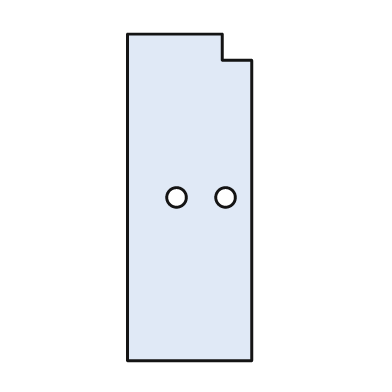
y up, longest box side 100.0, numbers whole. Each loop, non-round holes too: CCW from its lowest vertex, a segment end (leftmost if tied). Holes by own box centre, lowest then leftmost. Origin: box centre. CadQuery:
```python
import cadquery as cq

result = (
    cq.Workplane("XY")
    .moveTo(-19.0, -50.0)
    .lineTo(19.0, -50.0)
    .lineTo(19.0, 42.0)
    .lineTo(10.0, 42.0)
    .lineTo(10.0, 50.0)
    .lineTo(-19.0, 50.0)
    .close()
    .moveTo(-4.0, 0.0)
    .circle(3.0)
    .moveTo(11.0, 0.0)
    .circle(3.0)
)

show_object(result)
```